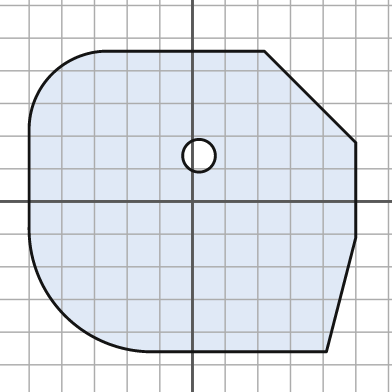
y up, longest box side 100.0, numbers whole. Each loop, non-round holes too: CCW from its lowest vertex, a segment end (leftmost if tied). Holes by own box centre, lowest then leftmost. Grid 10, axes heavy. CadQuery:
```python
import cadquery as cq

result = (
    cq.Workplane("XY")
    .moveTo(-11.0, -46.0)
    .lineTo(41.0, -46.0)
    .lineTo(50.0, -11.0)
    .lineTo(50.0, 18.0)
    .lineTo(22.0, 46.0)
    .lineTo(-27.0, 46.0)
    .threePointArc((-43.0, 39.0), (-50.0, 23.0))
    .lineTo(-50.0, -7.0)
    .threePointArc((-39.0, -35.0), (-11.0, -46.0))
    .close()
    .moveTo(2.0, 14.0)
    .circle(5.0)
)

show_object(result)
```